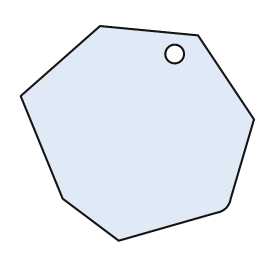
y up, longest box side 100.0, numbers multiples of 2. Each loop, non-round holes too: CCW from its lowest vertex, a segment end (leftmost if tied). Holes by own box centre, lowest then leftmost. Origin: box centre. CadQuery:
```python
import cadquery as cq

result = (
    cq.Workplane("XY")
    .moveTo(-8.0, -46.0)
    .lineTo(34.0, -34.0)
    .threePointArc((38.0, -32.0), (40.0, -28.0))
    .lineTo(50.0, 6.0)
    .lineTo(26.0, 42.0)
    .lineTo(-16.0, 46.0)
    .lineTo(-50.0, 16.0)
    .lineTo(-32.0, -28.0)
    .close()
    .moveTo(16.0, 34.0)
    .circle(4.0)
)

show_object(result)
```